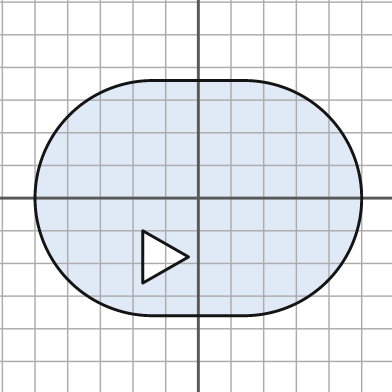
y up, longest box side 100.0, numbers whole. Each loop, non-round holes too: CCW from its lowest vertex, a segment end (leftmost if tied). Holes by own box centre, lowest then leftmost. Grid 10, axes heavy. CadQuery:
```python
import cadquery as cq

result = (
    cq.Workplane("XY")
    .moveTo(-14.0, -36.0)
    .lineTo(14.0, -36.0)
    .threePointArc((50.0, 0.0), (14.0, 36.0))
    .lineTo(-14.0, 36.0)
    .threePointArc((-50.0, 0.0), (-14.0, -36.0))
    .close()
    .moveTo(-17.0, -26.0)
    .lineTo(-3.0, -18.0)
    .lineTo(-17.0, -10.0)
    .close()
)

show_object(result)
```